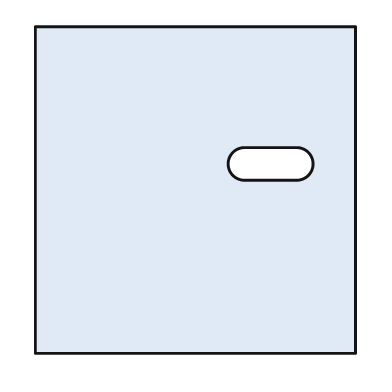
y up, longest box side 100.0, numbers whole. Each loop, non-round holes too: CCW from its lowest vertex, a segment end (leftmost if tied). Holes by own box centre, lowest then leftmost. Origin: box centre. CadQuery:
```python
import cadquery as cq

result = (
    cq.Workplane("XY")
    .moveTo(-49.0, -50.0)
    .lineTo(49.0, -50.0)
    .lineTo(49.0, 50.0)
    .lineTo(-49.0, 50.0)
    .close()
    .moveTo(15.0, 3.0)
    .lineTo(31.0, 3.0)
    .threePointArc((36.0, 8.0), (31.0, 13.0))
    .lineTo(15.0, 13.0)
    .threePointArc((10.0, 8.0), (15.0, 3.0))
    .close()
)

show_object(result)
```